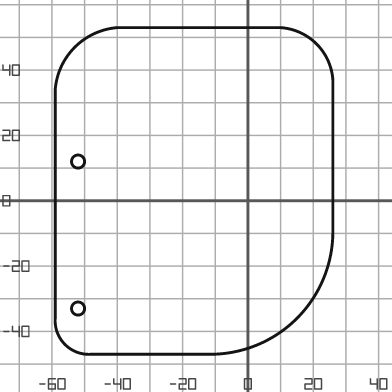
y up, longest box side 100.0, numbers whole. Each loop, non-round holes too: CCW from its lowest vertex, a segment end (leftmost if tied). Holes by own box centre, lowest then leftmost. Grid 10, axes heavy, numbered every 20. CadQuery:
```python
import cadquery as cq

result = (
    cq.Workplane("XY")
    .moveTo(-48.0, -47.0)
    .lineTo(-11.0, -47.0)
    .threePointArc((15.0, -36.0), (26.0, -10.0))
    .lineTo(26.0, 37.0)
    .threePointArc((21.0, 48.0), (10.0, 53.0))
    .lineTo(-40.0, 53.0)
    .threePointArc((-53.0, 47.0), (-59.0, 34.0))
    .lineTo(-59.0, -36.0)
    .threePointArc((-56.0, -44.0), (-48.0, -47.0))
    .close()
    .moveTo(-52.0, -33.0)
    .circle(2.0)
    .moveTo(-52.0, 12.0)
    .circle(2.0)
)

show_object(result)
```